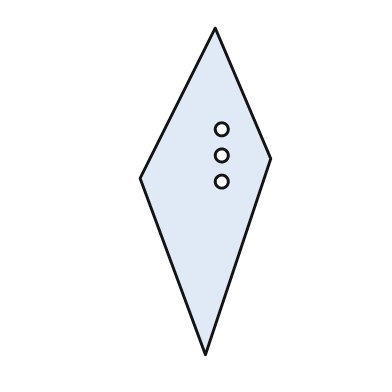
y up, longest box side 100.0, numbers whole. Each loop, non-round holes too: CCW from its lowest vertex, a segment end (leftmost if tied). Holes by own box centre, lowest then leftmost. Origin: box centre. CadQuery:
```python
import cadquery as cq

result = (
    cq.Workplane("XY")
    .moveTo(0.0, -50.0)
    .lineTo(20.0, 10.0)
    .lineTo(3.0, 50.0)
    .lineTo(-20.0, 4.0)
    .close()
    .moveTo(5.0, 3.0)
    .circle(2.0)
    .moveTo(5.0, 11.0)
    .circle(2.0)
    .moveTo(5.0, 19.0)
    .circle(2.0)
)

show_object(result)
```